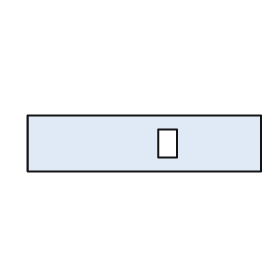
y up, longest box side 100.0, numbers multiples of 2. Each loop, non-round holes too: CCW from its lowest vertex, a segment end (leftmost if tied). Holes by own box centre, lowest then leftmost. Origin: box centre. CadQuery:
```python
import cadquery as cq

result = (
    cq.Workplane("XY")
    .moveTo(-50.0, -12.0)
    .lineTo(50.0, -12.0)
    .lineTo(50.0, 12.0)
    .lineTo(-50.0, 12.0)
    .close()
    .moveTo(6.0, -6.0)
    .lineTo(14.0, -6.0)
    .lineTo(14.0, 6.0)
    .lineTo(6.0, 6.0)
    .close()
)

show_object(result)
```